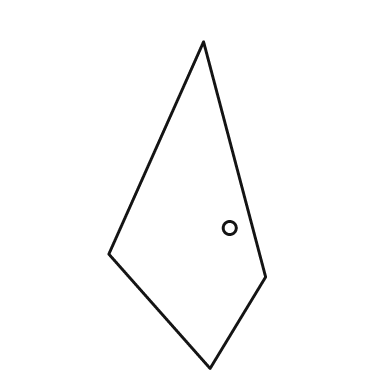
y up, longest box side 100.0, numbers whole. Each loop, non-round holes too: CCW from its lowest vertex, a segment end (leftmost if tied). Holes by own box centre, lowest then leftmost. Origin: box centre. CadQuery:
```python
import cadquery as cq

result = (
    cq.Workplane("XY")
    .moveTo(7.0, -50.0)
    .lineTo(24.0, -22.0)
    .lineTo(5.0, 50.0)
    .lineTo(-24.0, -15.0)
    .close()
    .moveTo(13.0, -7.0)
    .circle(2.0)
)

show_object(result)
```